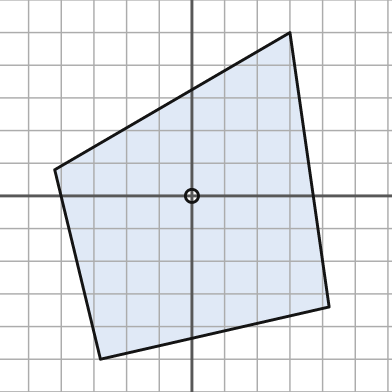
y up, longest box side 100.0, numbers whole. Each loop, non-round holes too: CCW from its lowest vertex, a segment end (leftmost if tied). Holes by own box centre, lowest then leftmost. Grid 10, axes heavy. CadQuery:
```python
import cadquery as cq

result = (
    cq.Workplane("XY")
    .moveTo(-28.0, -50.0)
    .lineTo(42.0, -34.0)
    .lineTo(30.0, 50.0)
    .lineTo(-42.0, 8.0)
    .close()
    .moveTo(0.0, 0.0)
    .circle(2.0)
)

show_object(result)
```